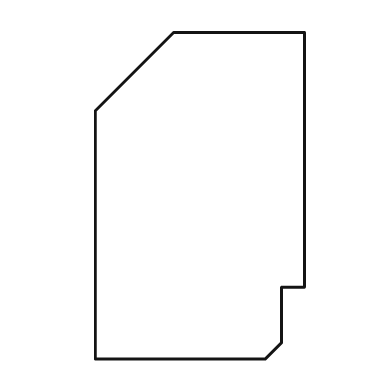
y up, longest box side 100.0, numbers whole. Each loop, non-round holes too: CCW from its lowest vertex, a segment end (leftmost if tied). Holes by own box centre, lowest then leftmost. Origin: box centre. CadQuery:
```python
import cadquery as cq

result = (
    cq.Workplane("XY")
    .moveTo(-32.0, -50.0)
    .lineTo(20.0, -50.0)
    .lineTo(25.0, -45.0)
    .lineTo(25.0, -28.0)
    .lineTo(32.0, -28.0)
    .lineTo(32.0, 50.0)
    .lineTo(-8.0, 50.0)
    .lineTo(-32.0, 26.0)
    .close()
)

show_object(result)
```